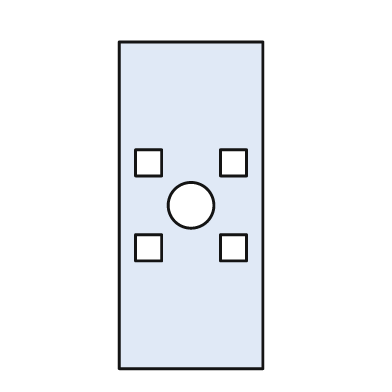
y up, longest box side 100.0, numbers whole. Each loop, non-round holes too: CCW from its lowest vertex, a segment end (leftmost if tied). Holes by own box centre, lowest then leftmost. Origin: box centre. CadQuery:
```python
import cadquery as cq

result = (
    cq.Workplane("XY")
    .moveTo(-22.0, -50.0)
    .lineTo(22.0, -50.0)
    .lineTo(22.0, 50.0)
    .lineTo(-22.0, 50.0)
    .close()
    .moveTo(-17.0, -17.0)
    .lineTo(-9.0, -17.0)
    .lineTo(-9.0, -9.0)
    .lineTo(-17.0, -9.0)
    .close()
    .moveTo(9.0, -17.0)
    .lineTo(17.0, -17.0)
    .lineTo(17.0, -9.0)
    .lineTo(9.0, -9.0)
    .close()
    .moveTo(0.0, 0.0)
    .circle(7.0)
    .moveTo(-17.0, 9.0)
    .lineTo(-9.0, 9.0)
    .lineTo(-9.0, 17.0)
    .lineTo(-17.0, 17.0)
    .close()
    .moveTo(9.0, 9.0)
    .lineTo(17.0, 9.0)
    .lineTo(17.0, 17.0)
    .lineTo(9.0, 17.0)
    .close()
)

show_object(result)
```